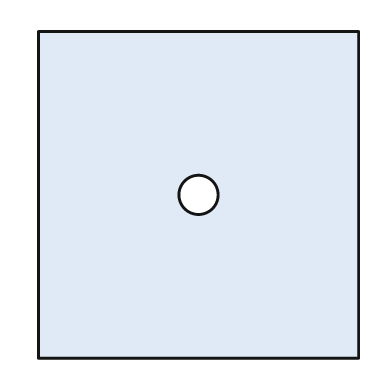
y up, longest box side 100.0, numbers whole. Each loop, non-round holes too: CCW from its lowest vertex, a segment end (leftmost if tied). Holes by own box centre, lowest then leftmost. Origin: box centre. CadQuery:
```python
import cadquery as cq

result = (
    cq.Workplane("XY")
    .moveTo(-49.0, -50.0)
    .lineTo(49.0, -50.0)
    .lineTo(49.0, 50.0)
    .lineTo(-49.0, 50.0)
    .close()
    .moveTo(0.0, 0.0)
    .circle(6.0)
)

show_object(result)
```